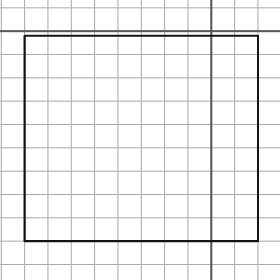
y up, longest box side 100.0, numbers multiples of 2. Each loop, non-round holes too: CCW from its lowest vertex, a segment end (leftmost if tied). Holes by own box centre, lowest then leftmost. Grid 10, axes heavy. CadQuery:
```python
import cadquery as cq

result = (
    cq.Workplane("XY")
    .moveTo(-80.0, -90.0)
    .lineTo(20.0, -90.0)
    .lineTo(20.0, -2.0)
    .lineTo(-80.0, -2.0)
    .close()
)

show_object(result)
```